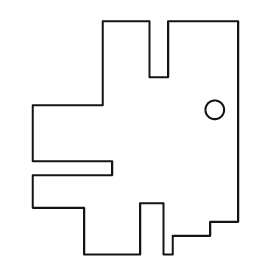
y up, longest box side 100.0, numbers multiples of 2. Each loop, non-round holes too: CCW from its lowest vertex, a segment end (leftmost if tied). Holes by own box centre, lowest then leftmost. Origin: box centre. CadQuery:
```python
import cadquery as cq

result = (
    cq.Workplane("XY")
    .moveTo(-22.0, -50.0)
    .lineTo(2.0, -50.0)
    .lineTo(2.0, -28.0)
    .lineTo(12.0, -28.0)
    .lineTo(12.0, -50.0)
    .lineTo(16.0, -50.0)
    .lineTo(16.0, -42.0)
    .lineTo(32.0, -42.0)
    .lineTo(32.0, -36.0)
    .lineTo(44.0, -36.0)
    .lineTo(44.0, 50.0)
    .lineTo(14.0, 50.0)
    .lineTo(14.0, 26.0)
    .lineTo(6.0, 26.0)
    .lineTo(6.0, 50.0)
    .lineTo(-14.0, 50.0)
    .lineTo(-14.0, 14.0)
    .lineTo(-44.0, 14.0)
    .lineTo(-44.0, -10.0)
    .lineTo(-10.0, -10.0)
    .lineTo(-10.0, -16.0)
    .lineTo(-44.0, -16.0)
    .lineTo(-44.0, -30.0)
    .lineTo(-22.0, -30.0)
    .close()
    .moveTo(34.0, 12.0)
    .circle(4.0)
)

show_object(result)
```